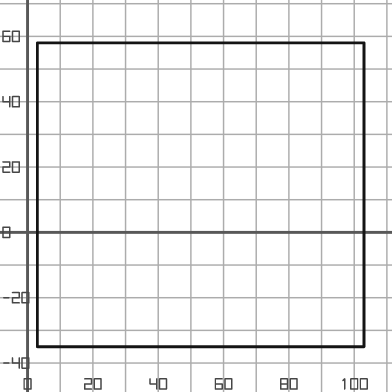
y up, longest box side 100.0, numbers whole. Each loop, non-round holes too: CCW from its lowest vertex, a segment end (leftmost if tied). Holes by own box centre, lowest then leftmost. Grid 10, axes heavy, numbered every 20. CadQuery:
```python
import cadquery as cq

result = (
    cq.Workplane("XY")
    .moveTo(3.0, -35.0)
    .lineTo(103.0, -35.0)
    .lineTo(103.0, 58.0)
    .lineTo(3.0, 58.0)
    .close()
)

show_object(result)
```